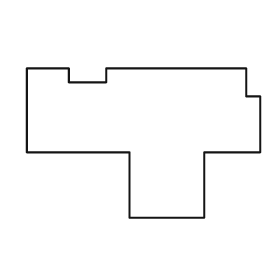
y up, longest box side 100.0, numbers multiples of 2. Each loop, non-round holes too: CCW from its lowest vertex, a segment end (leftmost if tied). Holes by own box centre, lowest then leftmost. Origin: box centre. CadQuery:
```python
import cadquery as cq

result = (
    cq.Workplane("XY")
    .moveTo(-6.0, -32.0)
    .lineTo(26.0, -32.0)
    .lineTo(26.0, -4.0)
    .lineTo(50.0, -4.0)
    .lineTo(50.0, 20.0)
    .lineTo(44.0, 20.0)
    .lineTo(44.0, 32.0)
    .lineTo(-16.0, 32.0)
    .lineTo(-16.0, 26.0)
    .lineTo(-32.0, 26.0)
    .lineTo(-32.0, 32.0)
    .lineTo(-50.0, 32.0)
    .lineTo(-50.0, -4.0)
    .lineTo(-6.0, -4.0)
    .close()
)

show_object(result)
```